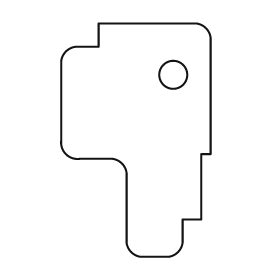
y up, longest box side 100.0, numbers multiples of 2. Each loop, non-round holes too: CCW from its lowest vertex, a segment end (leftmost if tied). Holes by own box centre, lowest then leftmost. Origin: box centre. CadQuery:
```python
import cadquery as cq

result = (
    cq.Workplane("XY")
    .moveTo(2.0, -50.0)
    .lineTo(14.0, -50.0)
    .threePointArc((18.0, -48.0), (20.0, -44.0))
    .lineTo(20.0, -34.0)
    .lineTo(28.0, -34.0)
    .lineTo(28.0, -6.0)
    .lineTo(32.0, -6.0)
    .lineTo(32.0, 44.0)
    .threePointArc((30.0, 48.0), (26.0, 50.0))
    .lineTo(-16.0, 50.0)
    .lineTo(-16.0, 40.0)
    .lineTo(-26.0, 40.0)
    .threePointArc((-30.0, 38.0), (-32.0, 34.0))
    .lineTo(-32.0, 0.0)
    .threePointArc((-30.0, -6.0), (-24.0, -8.0))
    .lineTo(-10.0, -8.0)
    .threePointArc((-6.0, -10.0), (-4.0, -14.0))
    .lineTo(-4.0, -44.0)
    .threePointArc((-2.0, -48.0), (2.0, -50.0))
    .close()
    .moveTo(16.0, 28.0)
    .circle(6.0)
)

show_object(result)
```